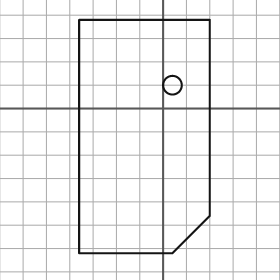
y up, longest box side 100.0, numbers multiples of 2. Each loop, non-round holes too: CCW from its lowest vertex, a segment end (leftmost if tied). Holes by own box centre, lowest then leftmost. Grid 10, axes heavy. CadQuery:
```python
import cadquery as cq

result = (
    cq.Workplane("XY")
    .moveTo(-36.0, -62.0)
    .lineTo(4.0, -62.0)
    .lineTo(20.0, -46.0)
    .lineTo(20.0, 38.0)
    .lineTo(-36.0, 38.0)
    .close()
    .moveTo(4.0, 10.0)
    .circle(4.0)
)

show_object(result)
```